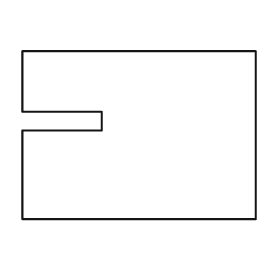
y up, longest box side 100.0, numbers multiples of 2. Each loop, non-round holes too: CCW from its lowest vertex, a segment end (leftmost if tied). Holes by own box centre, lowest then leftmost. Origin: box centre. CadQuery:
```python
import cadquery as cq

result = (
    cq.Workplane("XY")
    .moveTo(-50.0, -36.0)
    .lineTo(50.0, -36.0)
    .lineTo(50.0, 36.0)
    .lineTo(-50.0, 36.0)
    .lineTo(-50.0, 10.0)
    .lineTo(-16.0, 10.0)
    .lineTo(-16.0, 2.0)
    .lineTo(-50.0, 2.0)
    .close()
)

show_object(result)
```